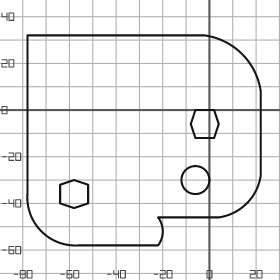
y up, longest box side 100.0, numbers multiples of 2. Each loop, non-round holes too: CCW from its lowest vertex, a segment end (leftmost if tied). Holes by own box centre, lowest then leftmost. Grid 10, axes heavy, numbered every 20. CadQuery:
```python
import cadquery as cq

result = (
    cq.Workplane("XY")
    .moveTo(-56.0, -58.0)
    .lineTo(-22.0, -58.0)
    .threePointArc((-20.0, -52.0), (-22.0, -46.0))
    .lineTo(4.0, -46.0)
    .threePointArc((16.0, -40.0), (22.0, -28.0))
    .lineTo(22.0, 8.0)
    .threePointArc((14.0, 24.0), (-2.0, 32.0))
    .lineTo(-78.0, 32.0)
    .lineTo(-78.0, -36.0)
    .threePointArc((-72.0, -52.0), (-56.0, -58.0))
    .close()
    .moveTo(-58.0, -42.0)
    .lineTo(-52.0, -40.0)
    .lineTo(-52.0, -32.0)
    .lineTo(-58.0, -30.0)
    .lineTo(-64.0, -32.0)
    .lineTo(-64.0, -40.0)
    .close()
    .moveTo(-6.0, -30.0)
    .circle(6.0)
    .moveTo(-6.0, -12.0)
    .lineTo(2.0, -12.0)
    .lineTo(4.0, -6.0)
    .lineTo(2.0, 0.0)
    .lineTo(-6.0, 0.0)
    .lineTo(-8.0, -6.0)
    .close()
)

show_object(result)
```